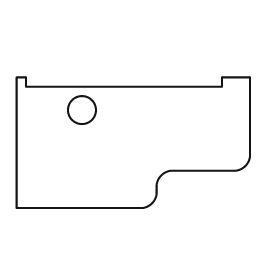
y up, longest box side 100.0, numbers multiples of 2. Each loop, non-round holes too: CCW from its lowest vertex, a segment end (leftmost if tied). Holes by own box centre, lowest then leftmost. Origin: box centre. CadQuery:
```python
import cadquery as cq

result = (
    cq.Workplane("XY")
    .moveTo(-50.0, -28.0)
    .lineTo(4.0, -28.0)
    .threePointArc((8.0, -26.0), (10.0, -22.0))
    .lineTo(10.0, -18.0)
    .threePointArc((12.0, -14.0), (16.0, -12.0))
    .lineTo(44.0, -12.0)
    .threePointArc((48.0, -10.0), (50.0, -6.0))
    .lineTo(50.0, 28.0)
    .lineTo(38.0, 28.0)
    .lineTo(38.0, 24.0)
    .lineTo(-46.0, 24.0)
    .lineTo(-46.0, 28.0)
    .lineTo(-50.0, 28.0)
    .close()
    .moveTo(-22.0, 14.0)
    .circle(6.0)
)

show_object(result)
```